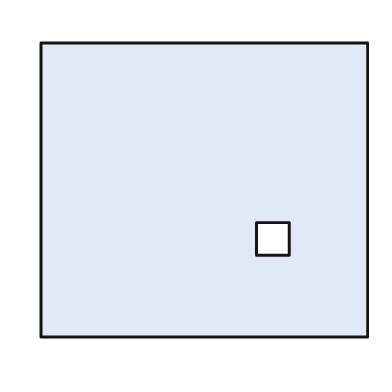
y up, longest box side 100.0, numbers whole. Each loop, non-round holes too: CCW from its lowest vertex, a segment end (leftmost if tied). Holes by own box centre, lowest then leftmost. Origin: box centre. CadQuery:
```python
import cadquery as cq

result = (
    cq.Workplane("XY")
    .moveTo(-50.0, -45.0)
    .lineTo(50.0, -45.0)
    .lineTo(50.0, 45.0)
    .lineTo(-50.0, 45.0)
    .close()
    .moveTo(16.0, -20.0)
    .lineTo(26.0, -20.0)
    .lineTo(26.0, -10.0)
    .lineTo(16.0, -10.0)
    .close()
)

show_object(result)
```